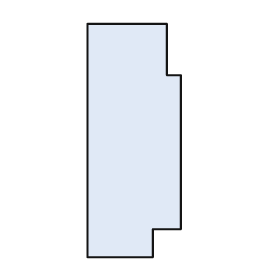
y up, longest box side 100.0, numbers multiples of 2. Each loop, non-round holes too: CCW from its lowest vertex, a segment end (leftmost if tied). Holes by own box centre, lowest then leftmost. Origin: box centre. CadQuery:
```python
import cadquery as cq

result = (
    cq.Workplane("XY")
    .moveTo(-20.0, -50.0)
    .lineTo(8.0, -50.0)
    .lineTo(8.0, -38.0)
    .lineTo(20.0, -38.0)
    .lineTo(20.0, 28.0)
    .lineTo(14.0, 28.0)
    .lineTo(14.0, 50.0)
    .lineTo(-20.0, 50.0)
    .close()
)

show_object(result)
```